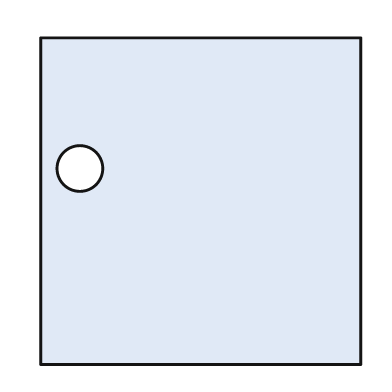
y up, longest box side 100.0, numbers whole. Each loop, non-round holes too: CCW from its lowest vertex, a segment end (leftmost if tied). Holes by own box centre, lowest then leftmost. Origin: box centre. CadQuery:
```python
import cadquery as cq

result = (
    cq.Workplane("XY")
    .moveTo(-49.0, -50.0)
    .lineTo(49.0, -50.0)
    .lineTo(49.0, 50.0)
    .lineTo(-49.0, 50.0)
    .close()
    .moveTo(-37.0, 10.0)
    .circle(7.0)
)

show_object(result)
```